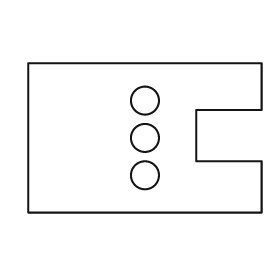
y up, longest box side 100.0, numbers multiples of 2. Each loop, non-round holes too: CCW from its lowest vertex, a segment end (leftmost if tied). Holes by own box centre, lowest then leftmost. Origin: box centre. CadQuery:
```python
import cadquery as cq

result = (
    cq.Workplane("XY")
    .moveTo(-50.0, -32.0)
    .lineTo(50.0, -32.0)
    .lineTo(50.0, -10.0)
    .lineTo(22.0, -10.0)
    .lineTo(22.0, 12.0)
    .lineTo(50.0, 12.0)
    .lineTo(50.0, 32.0)
    .lineTo(-50.0, 32.0)
    .close()
    .moveTo(0.0, -16.0)
    .circle(6.0)
    .moveTo(0.0, 0.0)
    .circle(6.0)
    .moveTo(0.0, 16.0)
    .circle(6.0)
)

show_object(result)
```